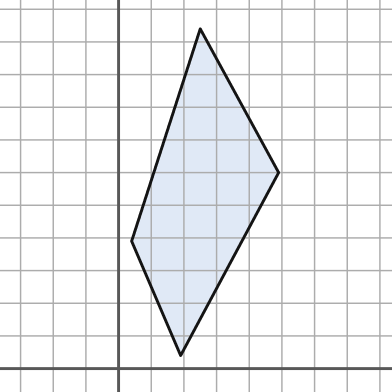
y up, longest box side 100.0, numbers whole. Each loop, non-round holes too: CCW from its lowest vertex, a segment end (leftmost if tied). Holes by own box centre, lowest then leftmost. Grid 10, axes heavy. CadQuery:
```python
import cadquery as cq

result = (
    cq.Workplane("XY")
    .moveTo(19.0, 4.0)
    .lineTo(49.0, 60.0)
    .lineTo(25.0, 104.0)
    .lineTo(4.0, 39.0)
    .close()
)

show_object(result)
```